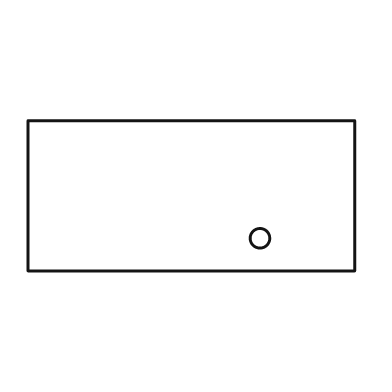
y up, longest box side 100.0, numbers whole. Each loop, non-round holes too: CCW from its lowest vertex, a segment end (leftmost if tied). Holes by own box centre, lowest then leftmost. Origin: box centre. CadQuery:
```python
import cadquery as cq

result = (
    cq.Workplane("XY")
    .moveTo(-50.0, -23.0)
    .lineTo(50.0, -23.0)
    .lineTo(50.0, 23.0)
    .lineTo(-50.0, 23.0)
    .close()
    .moveTo(21.0, -13.0)
    .circle(3.0)
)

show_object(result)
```